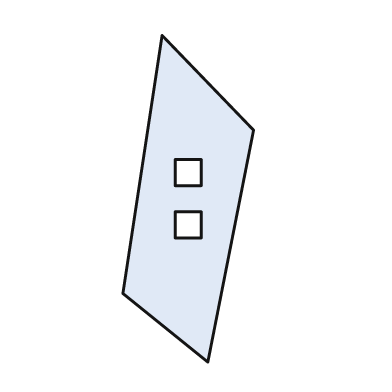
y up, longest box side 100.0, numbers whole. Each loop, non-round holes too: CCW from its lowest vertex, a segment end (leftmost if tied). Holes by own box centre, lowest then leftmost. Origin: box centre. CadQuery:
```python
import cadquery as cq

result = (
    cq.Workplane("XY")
    .moveTo(6.0, -50.0)
    .lineTo(20.0, 21.0)
    .lineTo(-8.0, 50.0)
    .lineTo(-20.0, -29.0)
    .close()
    .moveTo(-4.0, -12.0)
    .lineTo(4.0, -12.0)
    .lineTo(4.0, -4.0)
    .lineTo(-4.0, -4.0)
    .close()
    .moveTo(-4.0, 4.0)
    .lineTo(4.0, 4.0)
    .lineTo(4.0, 12.0)
    .lineTo(-4.0, 12.0)
    .close()
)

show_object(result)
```